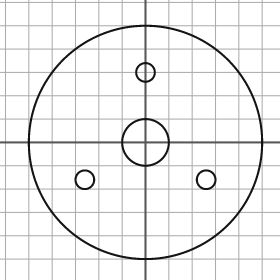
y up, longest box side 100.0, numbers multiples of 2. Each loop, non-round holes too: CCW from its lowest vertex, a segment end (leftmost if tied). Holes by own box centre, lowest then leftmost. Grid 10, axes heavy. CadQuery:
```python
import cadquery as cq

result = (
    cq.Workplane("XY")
    .moveTo(0.0, 0.0)
    .circle(50.0)
    .moveTo(-26.0, -16.0)
    .circle(4.0)
    .moveTo(26.0, -16.0)
    .circle(4.0)
    .moveTo(0.0, 0.0)
    .circle(10.0)
    .moveTo(0.0, 30.0)
    .circle(4.0)
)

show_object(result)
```